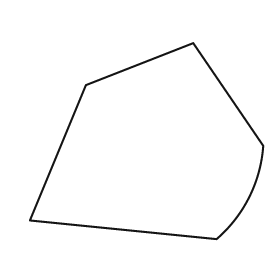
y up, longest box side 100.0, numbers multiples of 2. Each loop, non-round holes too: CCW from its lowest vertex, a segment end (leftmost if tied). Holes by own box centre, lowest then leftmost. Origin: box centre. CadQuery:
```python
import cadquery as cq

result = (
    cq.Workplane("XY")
    .moveTo(30.0, -42.0)
    .threePointArc((44.0, -24.0), (50.0, -2.0))
    .lineTo(20.0, 42.0)
    .lineTo(-26.0, 24.0)
    .lineTo(-50.0, -34.0)
    .close()
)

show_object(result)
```